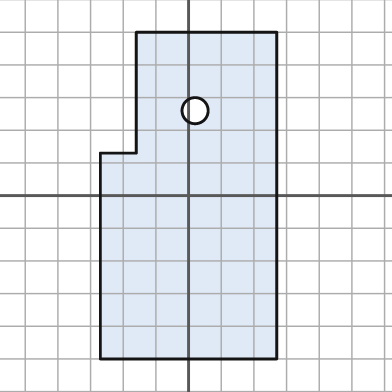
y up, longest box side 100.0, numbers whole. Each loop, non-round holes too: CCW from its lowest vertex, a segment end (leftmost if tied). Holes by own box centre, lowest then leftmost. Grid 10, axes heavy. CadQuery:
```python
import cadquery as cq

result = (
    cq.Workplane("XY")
    .moveTo(-27.0, -50.0)
    .lineTo(27.0, -50.0)
    .lineTo(27.0, 50.0)
    .lineTo(-16.0, 50.0)
    .lineTo(-16.0, 13.0)
    .lineTo(-27.0, 13.0)
    .close()
    .moveTo(2.0, 26.0)
    .circle(4.0)
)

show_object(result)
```